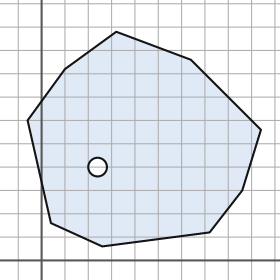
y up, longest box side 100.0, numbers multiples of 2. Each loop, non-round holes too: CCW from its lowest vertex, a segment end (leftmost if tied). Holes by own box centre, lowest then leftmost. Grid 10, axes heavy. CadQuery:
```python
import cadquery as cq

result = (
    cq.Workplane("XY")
    .moveTo(26.0, 6.0)
    .lineTo(72.0, 12.0)
    .lineTo(86.0, 30.0)
    .lineTo(94.0, 56.0)
    .lineTo(64.0, 86.0)
    .lineTo(32.0, 98.0)
    .lineTo(10.0, 82.0)
    .lineTo(-6.0, 60.0)
    .lineTo(4.0, 16.0)
    .close()
    .moveTo(24.0, 40.0)
    .circle(4.0)
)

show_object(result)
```